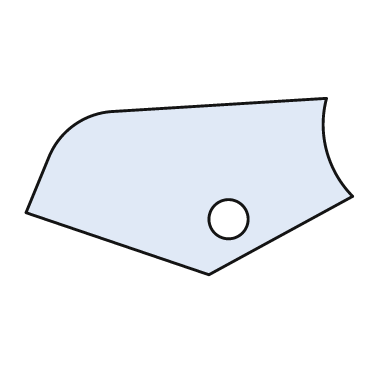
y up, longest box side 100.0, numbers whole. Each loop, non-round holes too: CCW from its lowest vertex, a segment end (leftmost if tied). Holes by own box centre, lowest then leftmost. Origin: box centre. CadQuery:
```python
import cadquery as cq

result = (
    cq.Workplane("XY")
    .moveTo(6.0, -27.0)
    .lineTo(50.0, -3.0)
    .threePointArc((42.0, 11.0), (42.0, 27.0))
    .lineTo(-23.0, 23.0)
    .threePointArc((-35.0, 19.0), (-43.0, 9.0))
    .lineTo(-50.0, -8.0)
    .close()
    .moveTo(12.0, -10.0)
    .circle(6.0)
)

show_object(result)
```